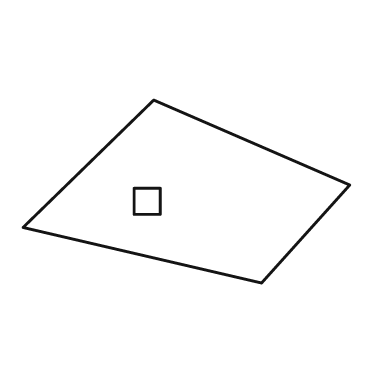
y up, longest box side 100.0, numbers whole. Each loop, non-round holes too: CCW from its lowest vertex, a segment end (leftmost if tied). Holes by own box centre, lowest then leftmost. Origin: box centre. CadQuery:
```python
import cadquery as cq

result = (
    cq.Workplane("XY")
    .moveTo(23.0, -28.0)
    .lineTo(50.0, 2.0)
    .lineTo(-10.0, 28.0)
    .lineTo(-50.0, -11.0)
    .close()
    .moveTo(-16.0, -7.0)
    .lineTo(-8.0, -7.0)
    .lineTo(-8.0, 1.0)
    .lineTo(-16.0, 1.0)
    .close()
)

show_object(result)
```